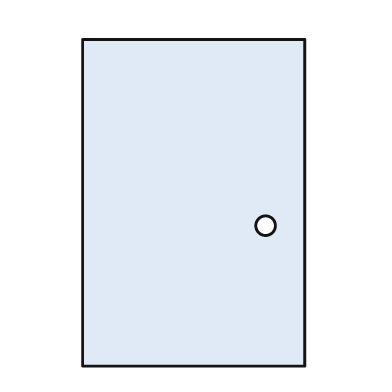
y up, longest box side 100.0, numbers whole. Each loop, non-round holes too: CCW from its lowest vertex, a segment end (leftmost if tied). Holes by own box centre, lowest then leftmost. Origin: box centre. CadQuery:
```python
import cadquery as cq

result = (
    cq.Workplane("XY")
    .moveTo(-34.0, -50.0)
    .lineTo(34.0, -50.0)
    .lineTo(34.0, 50.0)
    .lineTo(-34.0, 50.0)
    .close()
    .moveTo(22.0, -7.0)
    .circle(3.0)
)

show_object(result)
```